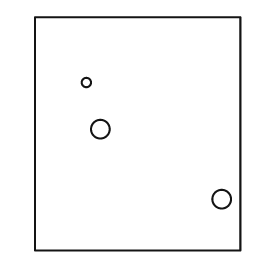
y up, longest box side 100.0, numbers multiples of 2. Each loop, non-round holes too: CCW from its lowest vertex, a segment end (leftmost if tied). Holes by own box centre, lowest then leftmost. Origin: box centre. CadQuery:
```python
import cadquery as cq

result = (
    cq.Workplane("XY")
    .moveTo(-44.0, -50.0)
    .lineTo(44.0, -50.0)
    .lineTo(44.0, 50.0)
    .lineTo(-44.0, 50.0)
    .close()
    .moveTo(36.0, -28.0)
    .circle(4.0)
    .moveTo(-16.0, 2.0)
    .circle(4.0)
    .moveTo(-22.0, 22.0)
    .circle(2.0)
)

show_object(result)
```